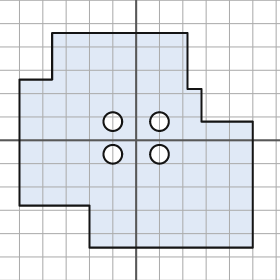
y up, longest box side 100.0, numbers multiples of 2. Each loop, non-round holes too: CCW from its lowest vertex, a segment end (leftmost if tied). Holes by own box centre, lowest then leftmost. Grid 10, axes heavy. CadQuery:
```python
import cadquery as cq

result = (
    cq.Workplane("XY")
    .moveTo(-20.0, -46.0)
    .lineTo(50.0, -46.0)
    .lineTo(50.0, 8.0)
    .lineTo(28.0, 8.0)
    .lineTo(28.0, 22.0)
    .lineTo(22.0, 22.0)
    .lineTo(22.0, 46.0)
    .lineTo(-36.0, 46.0)
    .lineTo(-36.0, 26.0)
    .lineTo(-50.0, 26.0)
    .lineTo(-50.0, -28.0)
    .lineTo(-20.0, -28.0)
    .close()
    .moveTo(-10.0, -6.0)
    .circle(4.0)
    .moveTo(10.0, -6.0)
    .circle(4.0)
    .moveTo(-10.0, 8.0)
    .circle(4.0)
    .moveTo(10.0, 8.0)
    .circle(4.0)
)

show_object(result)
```